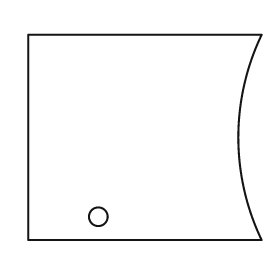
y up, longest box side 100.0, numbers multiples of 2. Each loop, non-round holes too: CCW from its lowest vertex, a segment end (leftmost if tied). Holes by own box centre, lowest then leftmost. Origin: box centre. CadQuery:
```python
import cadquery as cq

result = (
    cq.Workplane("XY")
    .moveTo(-50.0, -44.0)
    .lineTo(50.0, -44.0)
    .threePointArc((40.0, 0.0), (50.0, 44.0))
    .lineTo(-50.0, 44.0)
    .close()
    .moveTo(-20.0, -34.0)
    .circle(4.0)
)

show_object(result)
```